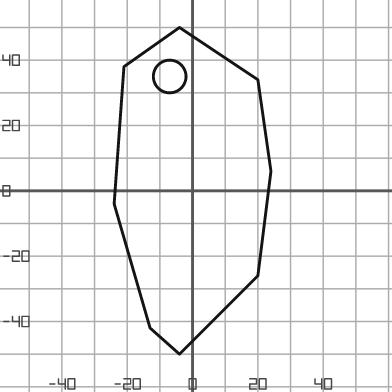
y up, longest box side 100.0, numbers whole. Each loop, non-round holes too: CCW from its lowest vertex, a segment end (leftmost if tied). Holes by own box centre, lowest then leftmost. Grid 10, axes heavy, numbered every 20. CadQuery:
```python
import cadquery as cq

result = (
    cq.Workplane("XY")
    .moveTo(-4.0, -50.0)
    .lineTo(20.0, -26.0)
    .lineTo(24.0, 6.0)
    .lineTo(20.0, 34.0)
    .lineTo(-4.0, 50.0)
    .lineTo(-21.0, 38.0)
    .lineTo(-24.0, -4.0)
    .lineTo(-13.0, -42.0)
    .close()
    .moveTo(-7.0, 35.0)
    .circle(5.0)
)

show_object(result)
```